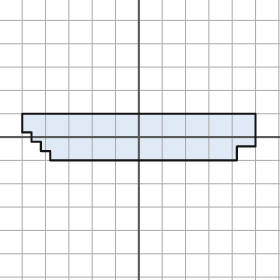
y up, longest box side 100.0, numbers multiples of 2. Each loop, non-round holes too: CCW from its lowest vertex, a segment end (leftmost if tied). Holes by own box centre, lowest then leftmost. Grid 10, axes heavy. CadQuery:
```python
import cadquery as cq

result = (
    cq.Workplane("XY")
    .moveTo(-38.0, -10.0)
    .lineTo(42.0, -10.0)
    .lineTo(42.0, -4.0)
    .lineTo(50.0, -4.0)
    .lineTo(50.0, 10.0)
    .lineTo(-50.0, 10.0)
    .lineTo(-50.0, 2.0)
    .lineTo(-46.0, 2.0)
    .lineTo(-46.0, -2.0)
    .lineTo(-42.0, -2.0)
    .lineTo(-42.0, -6.0)
    .lineTo(-38.0, -6.0)
    .close()
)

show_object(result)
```